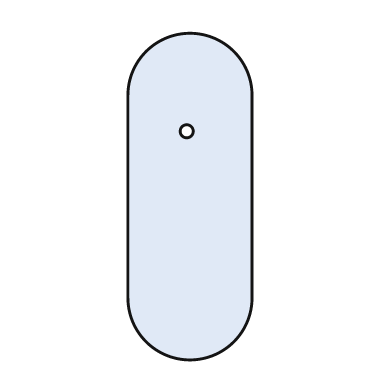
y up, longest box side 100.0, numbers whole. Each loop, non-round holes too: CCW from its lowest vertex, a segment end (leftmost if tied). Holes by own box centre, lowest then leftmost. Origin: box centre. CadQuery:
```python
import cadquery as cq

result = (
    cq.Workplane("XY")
    .moveTo(-19.0, -31.0)
    .threePointArc((0.0, -50.0), (19.0, -31.0))
    .lineTo(19.0, 31.0)
    .threePointArc((0.0, 50.0), (-19.0, 31.0))
    .close()
    .moveTo(-1.0, 20.0)
    .circle(2.0)
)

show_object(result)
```